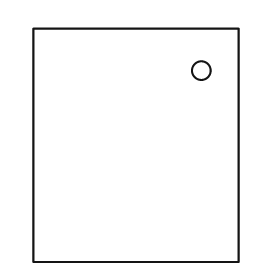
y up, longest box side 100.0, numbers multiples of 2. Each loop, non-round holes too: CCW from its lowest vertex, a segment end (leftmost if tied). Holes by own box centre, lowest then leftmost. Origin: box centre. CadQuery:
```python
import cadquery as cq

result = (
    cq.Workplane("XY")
    .moveTo(-44.0, -50.0)
    .lineTo(44.0, -50.0)
    .lineTo(44.0, 50.0)
    .lineTo(-44.0, 50.0)
    .close()
    .moveTo(28.0, 32.0)
    .circle(4.0)
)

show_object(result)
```